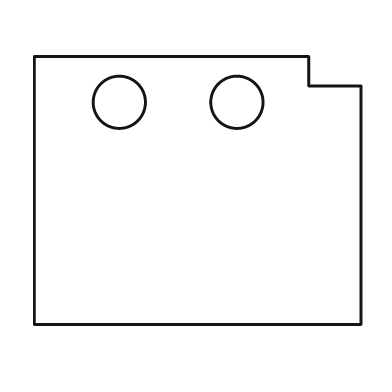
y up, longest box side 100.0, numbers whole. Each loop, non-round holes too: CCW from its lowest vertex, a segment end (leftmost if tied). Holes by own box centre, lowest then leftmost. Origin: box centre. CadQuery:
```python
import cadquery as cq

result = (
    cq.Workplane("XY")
    .moveTo(-50.0, -41.0)
    .lineTo(50.0, -41.0)
    .lineTo(50.0, 32.0)
    .lineTo(34.0, 32.0)
    .lineTo(34.0, 41.0)
    .lineTo(-50.0, 41.0)
    .close()
    .moveTo(-24.0, 27.0)
    .circle(8.0)
    .moveTo(12.0, 27.0)
    .circle(8.0)
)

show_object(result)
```